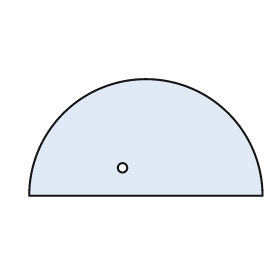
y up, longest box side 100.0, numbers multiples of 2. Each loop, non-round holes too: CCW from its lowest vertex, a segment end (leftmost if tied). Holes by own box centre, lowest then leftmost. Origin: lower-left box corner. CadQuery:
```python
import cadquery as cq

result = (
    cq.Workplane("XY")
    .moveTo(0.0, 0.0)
    .lineTo(100.0, 0.0)
    .threePointArc((50.0, 50.0), (0.0, 0.0))
    .close()
    .moveTo(40.0, 12.0)
    .circle(2.0)
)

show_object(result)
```